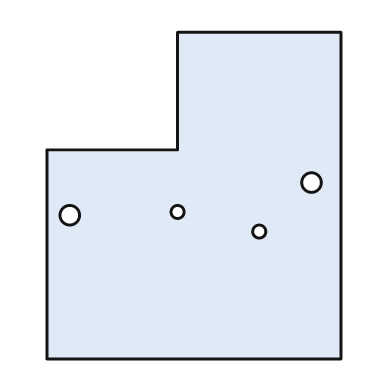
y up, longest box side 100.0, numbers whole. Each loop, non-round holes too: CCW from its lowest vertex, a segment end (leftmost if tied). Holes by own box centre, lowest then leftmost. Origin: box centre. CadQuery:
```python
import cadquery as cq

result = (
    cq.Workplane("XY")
    .moveTo(-45.0, -50.0)
    .lineTo(45.0, -50.0)
    .lineTo(45.0, 50.0)
    .lineTo(-5.0, 50.0)
    .lineTo(-5.0, 14.0)
    .lineTo(-45.0, 14.0)
    .close()
    .moveTo(20.0, -11.0)
    .circle(2.0)
    .moveTo(-38.0, -6.0)
    .circle(3.0)
    .moveTo(-5.0, -5.0)
    .circle(2.0)
    .moveTo(36.0, 4.0)
    .circle(3.0)
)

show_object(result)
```